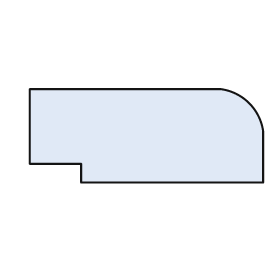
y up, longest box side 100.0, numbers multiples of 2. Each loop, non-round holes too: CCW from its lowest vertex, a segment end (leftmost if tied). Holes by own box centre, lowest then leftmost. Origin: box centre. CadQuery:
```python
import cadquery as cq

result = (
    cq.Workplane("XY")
    .moveTo(-28.0, -20.0)
    .lineTo(50.0, -20.0)
    .lineTo(50.0, 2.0)
    .threePointArc((44.0, 14.0), (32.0, 20.0))
    .lineTo(-50.0, 20.0)
    .lineTo(-50.0, -12.0)
    .lineTo(-28.0, -12.0)
    .close()
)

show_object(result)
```